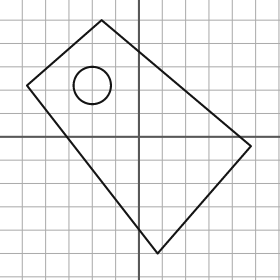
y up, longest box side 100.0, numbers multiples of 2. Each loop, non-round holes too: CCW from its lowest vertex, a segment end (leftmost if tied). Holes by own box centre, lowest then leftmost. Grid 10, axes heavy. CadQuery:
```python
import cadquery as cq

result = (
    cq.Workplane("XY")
    .moveTo(8.0, -50.0)
    .lineTo(48.0, -4.0)
    .lineTo(-16.0, 50.0)
    .lineTo(-48.0, 22.0)
    .close()
    .moveTo(-20.0, 22.0)
    .circle(8.0)
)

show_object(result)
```